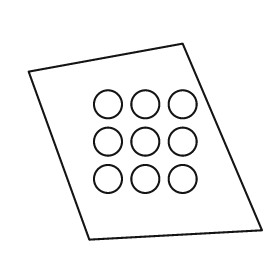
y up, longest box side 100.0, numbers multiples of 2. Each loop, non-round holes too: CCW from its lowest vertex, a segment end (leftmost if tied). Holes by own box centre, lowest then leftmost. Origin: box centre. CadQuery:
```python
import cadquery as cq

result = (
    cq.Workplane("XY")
    .moveTo(-24.0, -42.0)
    .lineTo(50.0, -38.0)
    .lineTo(16.0, 42.0)
    .lineTo(-50.0, 30.0)
    .close()
    .moveTo(-16.0, -16.0)
    .circle(6.0)
    .moveTo(0.0, -16.0)
    .circle(6.0)
    .moveTo(16.0, -16.0)
    .circle(6.0)
    .moveTo(-16.0, 0.0)
    .circle(6.0)
    .moveTo(0.0, 0.0)
    .circle(6.0)
    .moveTo(16.0, 0.0)
    .circle(6.0)
    .moveTo(-16.0, 16.0)
    .circle(6.0)
    .moveTo(0.0, 16.0)
    .circle(6.0)
    .moveTo(16.0, 16.0)
    .circle(6.0)
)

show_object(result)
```